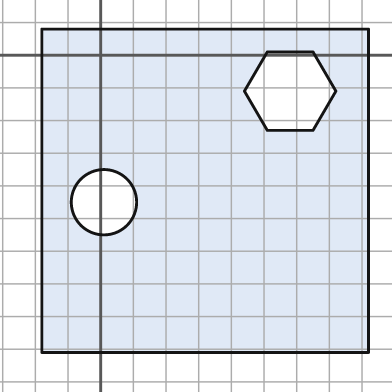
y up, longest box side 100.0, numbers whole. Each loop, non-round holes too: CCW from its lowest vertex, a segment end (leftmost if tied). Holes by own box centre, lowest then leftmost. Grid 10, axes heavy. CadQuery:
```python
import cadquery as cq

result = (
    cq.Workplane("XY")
    .moveTo(-18.0, -91.0)
    .lineTo(82.0, -91.0)
    .lineTo(82.0, 8.0)
    .lineTo(-18.0, 8.0)
    .close()
    .moveTo(1.0, -45.0)
    .circle(10.0)
    .moveTo(51.0, -23.0)
    .lineTo(65.0, -23.0)
    .lineTo(72.0, -11.0)
    .lineTo(65.0, 1.0)
    .lineTo(51.0, 1.0)
    .lineTo(44.0, -11.0)
    .close()
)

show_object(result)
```